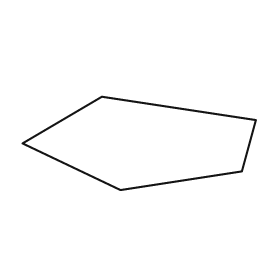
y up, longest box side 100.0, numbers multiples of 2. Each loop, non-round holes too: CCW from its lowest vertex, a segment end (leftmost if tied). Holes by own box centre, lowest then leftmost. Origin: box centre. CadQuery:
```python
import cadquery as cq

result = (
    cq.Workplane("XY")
    .moveTo(-8.0, -20.0)
    .lineTo(44.0, -12.0)
    .lineTo(50.0, 10.0)
    .lineTo(-16.0, 20.0)
    .lineTo(-50.0, 0.0)
    .close()
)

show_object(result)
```